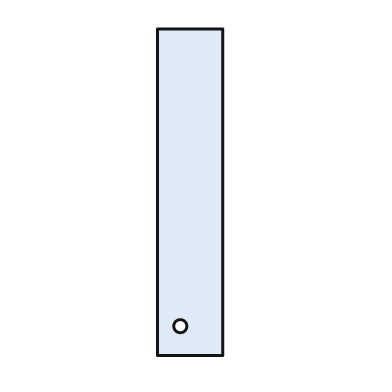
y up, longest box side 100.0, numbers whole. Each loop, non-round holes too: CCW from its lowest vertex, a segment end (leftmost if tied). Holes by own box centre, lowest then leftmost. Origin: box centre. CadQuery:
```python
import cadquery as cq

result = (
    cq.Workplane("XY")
    .moveTo(-10.0, -50.0)
    .lineTo(10.0, -50.0)
    .lineTo(10.0, 50.0)
    .lineTo(-10.0, 50.0)
    .close()
    .moveTo(-3.0, -41.0)
    .circle(2.0)
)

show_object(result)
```